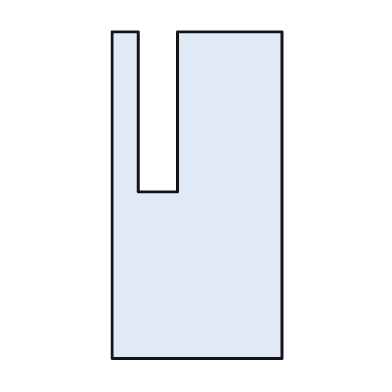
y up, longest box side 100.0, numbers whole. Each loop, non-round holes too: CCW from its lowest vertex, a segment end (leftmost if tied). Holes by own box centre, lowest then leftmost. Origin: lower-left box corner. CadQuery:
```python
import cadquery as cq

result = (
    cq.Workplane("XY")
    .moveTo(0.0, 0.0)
    .lineTo(52.0, 0.0)
    .lineTo(52.0, 100.0)
    .lineTo(20.0, 100.0)
    .lineTo(20.0, 51.0)
    .lineTo(8.0, 51.0)
    .lineTo(8.0, 100.0)
    .lineTo(0.0, 100.0)
    .close()
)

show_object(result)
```